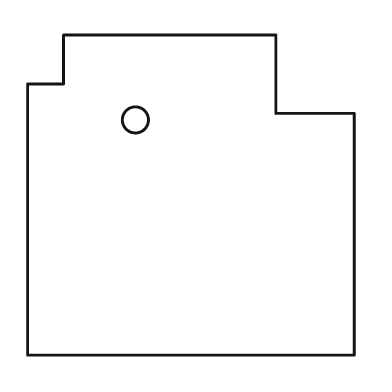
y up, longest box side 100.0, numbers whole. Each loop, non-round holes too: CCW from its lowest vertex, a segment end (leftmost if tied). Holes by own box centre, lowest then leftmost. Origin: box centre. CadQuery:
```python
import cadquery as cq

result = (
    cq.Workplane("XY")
    .moveTo(-50.0, -49.0)
    .lineTo(50.0, -49.0)
    .lineTo(50.0, 25.0)
    .lineTo(26.0, 25.0)
    .lineTo(26.0, 49.0)
    .lineTo(-39.0, 49.0)
    .lineTo(-39.0, 34.0)
    .lineTo(-50.0, 34.0)
    .close()
    .moveTo(-17.0, 23.0)
    .circle(4.0)
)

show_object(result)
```